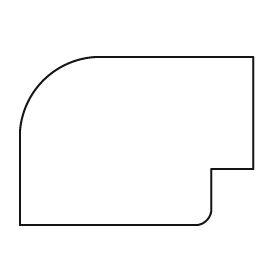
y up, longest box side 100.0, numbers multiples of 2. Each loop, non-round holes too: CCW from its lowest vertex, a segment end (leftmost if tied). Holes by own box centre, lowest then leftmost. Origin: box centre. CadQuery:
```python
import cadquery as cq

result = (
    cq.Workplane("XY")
    .moveTo(-50.0, -36.0)
    .lineTo(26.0, -36.0)
    .threePointArc((30.0, -34.0), (32.0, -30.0))
    .lineTo(32.0, -12.0)
    .lineTo(50.0, -12.0)
    .lineTo(50.0, 36.0)
    .lineTo(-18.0, 36.0)
    .threePointArc((-40.0, 26.0), (-50.0, 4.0))
    .close()
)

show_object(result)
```